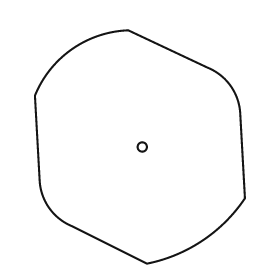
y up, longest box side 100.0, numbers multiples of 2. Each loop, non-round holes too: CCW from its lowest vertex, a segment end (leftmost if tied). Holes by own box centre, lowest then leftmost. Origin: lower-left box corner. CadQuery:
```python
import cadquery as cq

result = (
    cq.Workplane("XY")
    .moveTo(48.0, 0.0)
    .threePointArc((72.0, 10.0), (90.0, 28.0))
    .lineTo(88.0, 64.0)
    .threePointArc((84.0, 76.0), (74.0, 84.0))
    .lineTo(40.0, 100.0)
    .threePointArc((16.0, 92.0), (0.0, 72.0))
    .lineTo(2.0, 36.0)
    .threePointArc((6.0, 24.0), (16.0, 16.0))
    .close()
    .moveTo(46.0, 50.0)
    .circle(2.0)
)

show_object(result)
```